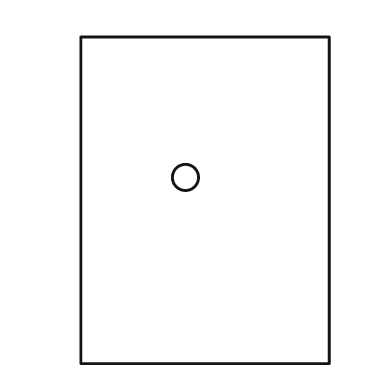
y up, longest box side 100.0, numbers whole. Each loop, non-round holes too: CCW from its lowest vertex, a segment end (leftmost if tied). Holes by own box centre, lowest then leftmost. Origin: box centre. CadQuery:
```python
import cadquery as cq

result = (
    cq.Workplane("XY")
    .moveTo(-38.0, -50.0)
    .lineTo(38.0, -50.0)
    .lineTo(38.0, 50.0)
    .lineTo(-38.0, 50.0)
    .close()
    .moveTo(-6.0, 7.0)
    .circle(4.0)
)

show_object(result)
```